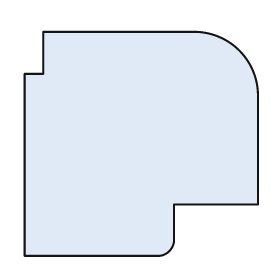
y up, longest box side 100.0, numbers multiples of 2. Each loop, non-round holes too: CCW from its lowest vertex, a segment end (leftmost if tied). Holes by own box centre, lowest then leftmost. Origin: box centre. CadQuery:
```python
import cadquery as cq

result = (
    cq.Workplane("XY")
    .moveTo(-50.0, -48.0)
    .lineTo(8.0, -48.0)
    .threePointArc((12.0, -46.0), (14.0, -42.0))
    .lineTo(14.0, -26.0)
    .lineTo(50.0, -26.0)
    .lineTo(50.0, 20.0)
    .threePointArc((42.0, 40.0), (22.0, 48.0))
    .lineTo(-42.0, 48.0)
    .lineTo(-42.0, 30.0)
    .lineTo(-50.0, 30.0)
    .close()
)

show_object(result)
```